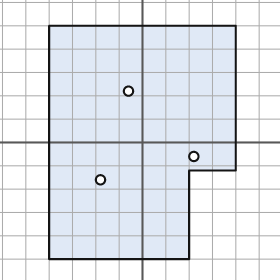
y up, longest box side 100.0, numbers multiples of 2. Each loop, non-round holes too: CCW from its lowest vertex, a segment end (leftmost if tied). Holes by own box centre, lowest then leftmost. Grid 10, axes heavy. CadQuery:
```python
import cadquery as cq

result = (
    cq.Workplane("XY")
    .moveTo(-40.0, -50.0)
    .lineTo(20.0, -50.0)
    .lineTo(20.0, -12.0)
    .lineTo(40.0, -12.0)
    .lineTo(40.0, 50.0)
    .lineTo(-40.0, 50.0)
    .close()
    .moveTo(-18.0, -16.0)
    .circle(2.0)
    .moveTo(22.0, -6.0)
    .circle(2.0)
    .moveTo(-6.0, 22.0)
    .circle(2.0)
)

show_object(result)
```